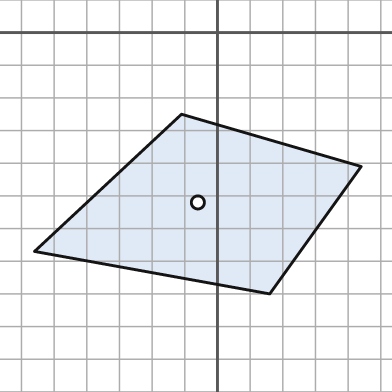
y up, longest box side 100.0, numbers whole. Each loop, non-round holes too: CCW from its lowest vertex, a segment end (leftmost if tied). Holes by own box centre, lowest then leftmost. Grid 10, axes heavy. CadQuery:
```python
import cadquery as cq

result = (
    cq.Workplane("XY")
    .moveTo(16.0, -80.0)
    .lineTo(44.0, -41.0)
    .lineTo(-11.0, -25.0)
    .lineTo(-56.0, -67.0)
    .close()
    .moveTo(-6.0, -52.0)
    .circle(2.0)
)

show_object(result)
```